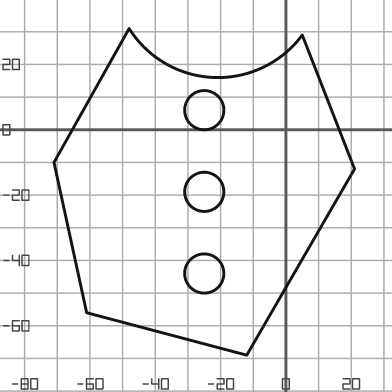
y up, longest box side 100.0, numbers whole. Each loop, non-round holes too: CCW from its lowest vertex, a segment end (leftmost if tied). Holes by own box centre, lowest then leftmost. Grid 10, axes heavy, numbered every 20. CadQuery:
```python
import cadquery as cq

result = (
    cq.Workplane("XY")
    .moveTo(-12.0, -69.0)
    .lineTo(21.0, -12.0)
    .lineTo(5.0, 29.0)
    .threePointArc((-22.0, 16.0), (-48.0, 31.0))
    .lineTo(-71.0, -10.0)
    .lineTo(-61.0, -56.0)
    .close()
    .moveTo(-25.0, -44.0)
    .circle(6.0)
    .moveTo(-25.0, -19.0)
    .circle(6.0)
    .moveTo(-25.0, 6.0)
    .circle(6.0)
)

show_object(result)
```